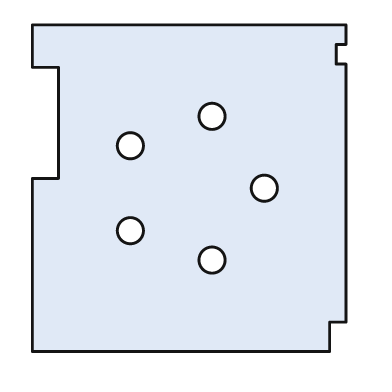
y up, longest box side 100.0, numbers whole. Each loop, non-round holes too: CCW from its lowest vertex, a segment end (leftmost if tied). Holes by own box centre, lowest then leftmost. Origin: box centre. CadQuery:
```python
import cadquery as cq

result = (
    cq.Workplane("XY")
    .moveTo(-48.0, -50.0)
    .lineTo(43.0, -50.0)
    .lineTo(43.0, -41.0)
    .lineTo(48.0, -41.0)
    .lineTo(48.0, 38.0)
    .lineTo(45.0, 38.0)
    .lineTo(45.0, 44.0)
    .lineTo(48.0, 44.0)
    .lineTo(48.0, 50.0)
    .lineTo(-48.0, 50.0)
    .lineTo(-48.0, 37.0)
    .lineTo(-40.0, 37.0)
    .lineTo(-40.0, 3.0)
    .lineTo(-48.0, 3.0)
    .close()
    .moveTo(7.0, -22.0)
    .circle(4.0)
    .moveTo(-18.0, -13.0)
    .circle(4.0)
    .moveTo(23.0, 0.0)
    .circle(4.0)
    .moveTo(-18.0, 13.0)
    .circle(4.0)
    .moveTo(7.0, 22.0)
    .circle(4.0)
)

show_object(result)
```